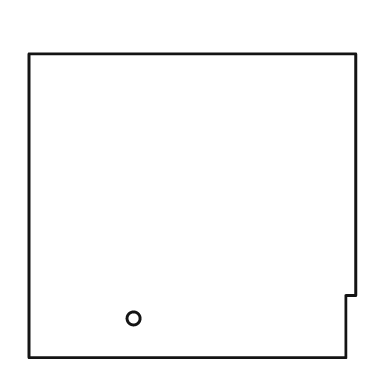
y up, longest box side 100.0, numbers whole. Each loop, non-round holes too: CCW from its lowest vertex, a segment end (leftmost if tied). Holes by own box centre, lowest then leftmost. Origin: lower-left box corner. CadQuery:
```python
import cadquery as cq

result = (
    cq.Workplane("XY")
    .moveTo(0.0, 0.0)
    .lineTo(97.0, 0.0)
    .lineTo(97.0, 19.0)
    .lineTo(100.0, 19.0)
    .lineTo(100.0, 93.0)
    .lineTo(0.0, 93.0)
    .close()
    .moveTo(32.0, 12.0)
    .circle(2.0)
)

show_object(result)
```